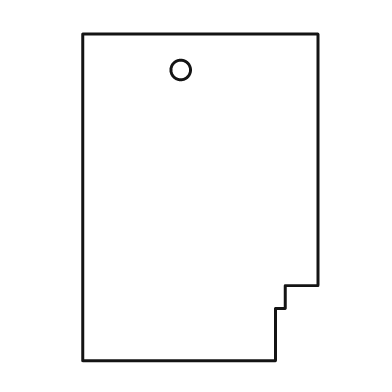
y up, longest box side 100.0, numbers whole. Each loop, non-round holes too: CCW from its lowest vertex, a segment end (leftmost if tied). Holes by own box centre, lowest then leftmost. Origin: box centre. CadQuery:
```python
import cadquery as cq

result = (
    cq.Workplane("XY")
    .moveTo(-36.0, -50.0)
    .lineTo(23.0, -50.0)
    .lineTo(23.0, -34.0)
    .lineTo(26.0, -34.0)
    .lineTo(26.0, -27.0)
    .lineTo(36.0, -27.0)
    .lineTo(36.0, 50.0)
    .lineTo(-36.0, 50.0)
    .close()
    .moveTo(-6.0, 39.0)
    .circle(3.0)
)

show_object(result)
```